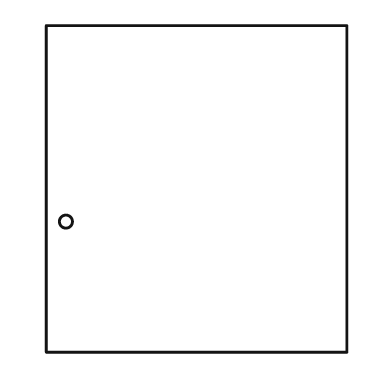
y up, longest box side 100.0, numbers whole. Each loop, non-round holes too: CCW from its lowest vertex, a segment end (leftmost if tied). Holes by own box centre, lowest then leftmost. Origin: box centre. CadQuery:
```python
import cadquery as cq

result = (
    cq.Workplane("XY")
    .moveTo(-46.0, -50.0)
    .lineTo(46.0, -50.0)
    .lineTo(46.0, 50.0)
    .lineTo(-46.0, 50.0)
    .close()
    .moveTo(-40.0, -10.0)
    .circle(2.0)
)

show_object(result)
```